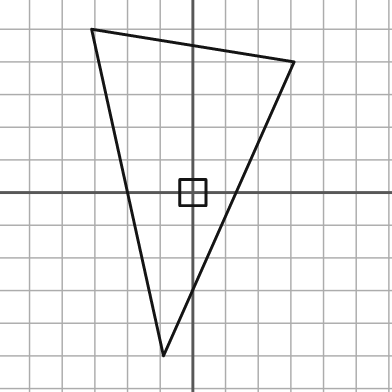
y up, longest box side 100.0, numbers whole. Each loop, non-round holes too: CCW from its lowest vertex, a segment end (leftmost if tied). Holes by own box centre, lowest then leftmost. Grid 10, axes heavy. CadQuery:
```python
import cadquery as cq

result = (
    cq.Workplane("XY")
    .moveTo(-9.0, -50.0)
    .lineTo(31.0, 40.0)
    .lineTo(-31.0, 50.0)
    .close()
    .moveTo(-4.0, -4.0)
    .lineTo(4.0, -4.0)
    .lineTo(4.0, 4.0)
    .lineTo(-4.0, 4.0)
    .close()
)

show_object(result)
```